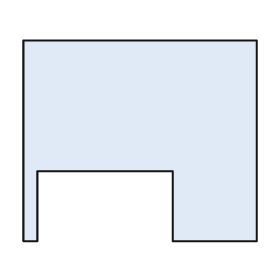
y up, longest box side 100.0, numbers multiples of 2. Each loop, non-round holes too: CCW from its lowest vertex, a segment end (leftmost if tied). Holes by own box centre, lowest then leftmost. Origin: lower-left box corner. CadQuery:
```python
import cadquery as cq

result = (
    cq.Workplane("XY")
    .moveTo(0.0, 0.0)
    .lineTo(6.0, 0.0)
    .lineTo(6.0, 30.0)
    .lineTo(64.0, 30.0)
    .lineTo(64.0, 0.0)
    .lineTo(100.0, 0.0)
    .lineTo(100.0, 86.0)
    .lineTo(0.0, 86.0)
    .close()
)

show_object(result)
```